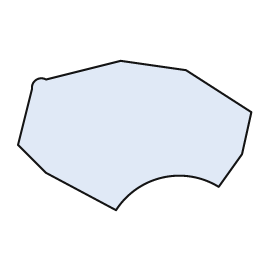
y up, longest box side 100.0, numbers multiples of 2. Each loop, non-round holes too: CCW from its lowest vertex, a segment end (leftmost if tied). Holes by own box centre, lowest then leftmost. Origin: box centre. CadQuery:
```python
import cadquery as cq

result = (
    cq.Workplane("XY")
    .moveTo(-8.0, -32.0)
    .threePointArc((12.0, -18.0), (36.0, -22.0))
    .lineTo(46.0, -8.0)
    .lineTo(50.0, 10.0)
    .lineTo(22.0, 28.0)
    .lineTo(-6.0, 32.0)
    .lineTo(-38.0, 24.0)
    .threePointArc((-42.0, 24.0), (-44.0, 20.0))
    .lineTo(-50.0, -4.0)
    .lineTo(-38.0, -16.0)
    .close()
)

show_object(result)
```